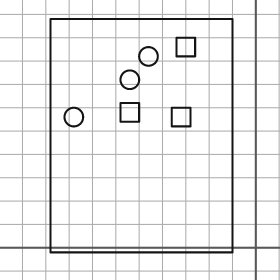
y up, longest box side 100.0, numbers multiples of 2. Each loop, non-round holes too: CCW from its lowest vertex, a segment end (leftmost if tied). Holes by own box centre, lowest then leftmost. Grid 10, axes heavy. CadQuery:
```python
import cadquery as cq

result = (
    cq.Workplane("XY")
    .moveTo(-88.0, -2.0)
    .lineTo(-10.0, -2.0)
    .lineTo(-10.0, 98.0)
    .lineTo(-88.0, 98.0)
    .close()
    .moveTo(-78.0, 56.0)
    .circle(4.0)
    .moveTo(-36.0, 52.0)
    .lineTo(-28.0, 52.0)
    .lineTo(-28.0, 60.0)
    .lineTo(-36.0, 60.0)
    .close()
    .moveTo(-58.0, 54.0)
    .lineTo(-50.0, 54.0)
    .lineTo(-50.0, 62.0)
    .lineTo(-58.0, 62.0)
    .close()
    .moveTo(-54.0, 72.0)
    .circle(4.0)
    .moveTo(-46.0, 82.0)
    .circle(4.0)
    .moveTo(-34.0, 82.0)
    .lineTo(-26.0, 82.0)
    .lineTo(-26.0, 90.0)
    .lineTo(-34.0, 90.0)
    .close()
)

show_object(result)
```